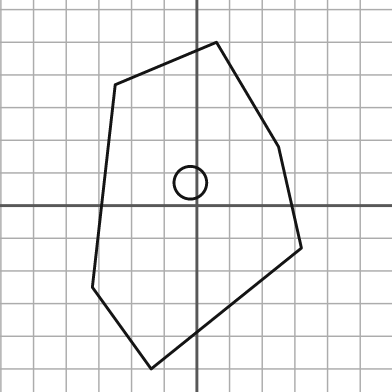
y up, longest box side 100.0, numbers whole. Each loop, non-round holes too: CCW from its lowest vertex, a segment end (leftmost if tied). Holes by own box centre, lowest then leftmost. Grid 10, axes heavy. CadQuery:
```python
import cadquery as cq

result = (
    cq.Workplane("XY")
    .moveTo(-14.0, -50.0)
    .lineTo(32.0, -13.0)
    .lineTo(25.0, 18.0)
    .lineTo(6.0, 50.0)
    .lineTo(-25.0, 37.0)
    .lineTo(-32.0, -25.0)
    .close()
    .moveTo(-2.0, 7.0)
    .circle(5.0)
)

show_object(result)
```